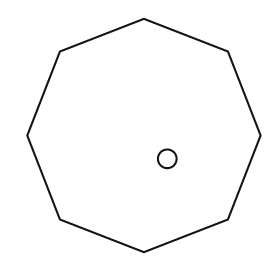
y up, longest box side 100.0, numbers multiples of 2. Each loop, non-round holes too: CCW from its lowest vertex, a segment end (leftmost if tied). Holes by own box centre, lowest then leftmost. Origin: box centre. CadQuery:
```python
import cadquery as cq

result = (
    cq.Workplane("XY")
    .moveTo(0.0, -50.0)
    .lineTo(36.0, -36.0)
    .lineTo(50.0, 0.0)
    .lineTo(36.0, 36.0)
    .lineTo(0.0, 50.0)
    .lineTo(-36.0, 36.0)
    .lineTo(-50.0, 0.0)
    .lineTo(-36.0, -36.0)
    .close()
    .moveTo(10.0, -10.0)
    .circle(4.0)
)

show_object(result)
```